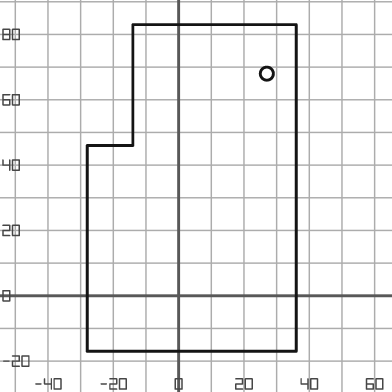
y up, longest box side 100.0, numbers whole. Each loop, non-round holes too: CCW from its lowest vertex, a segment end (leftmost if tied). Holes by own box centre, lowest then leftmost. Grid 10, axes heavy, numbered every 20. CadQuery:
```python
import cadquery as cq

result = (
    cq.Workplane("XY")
    .moveTo(-28.0, -17.0)
    .lineTo(36.0, -17.0)
    .lineTo(36.0, 83.0)
    .lineTo(-14.0, 83.0)
    .lineTo(-14.0, 46.0)
    .lineTo(-28.0, 46.0)
    .close()
    .moveTo(27.0, 68.0)
    .circle(2.0)
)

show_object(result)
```